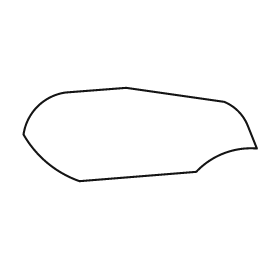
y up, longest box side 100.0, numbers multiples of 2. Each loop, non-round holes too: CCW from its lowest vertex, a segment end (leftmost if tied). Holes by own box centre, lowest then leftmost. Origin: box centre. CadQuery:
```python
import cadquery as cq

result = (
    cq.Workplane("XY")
    .moveTo(-26.0, -20.0)
    .lineTo(24.0, -16.0)
    .threePointArc((36.0, -8.0), (50.0, -6.0))
    .lineTo(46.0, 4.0)
    .threePointArc((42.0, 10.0), (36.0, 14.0))
    .lineTo(-6.0, 20.0)
    .lineTo(-32.0, 18.0)
    .threePointArc((-44.0, 12.0), (-50.0, 0.0))
    .threePointArc((-40.0, -12.0), (-26.0, -20.0))
    .close()
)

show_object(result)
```